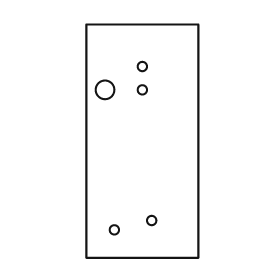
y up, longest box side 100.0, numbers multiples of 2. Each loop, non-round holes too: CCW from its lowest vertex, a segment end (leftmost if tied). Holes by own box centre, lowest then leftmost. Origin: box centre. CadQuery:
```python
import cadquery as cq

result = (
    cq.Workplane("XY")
    .moveTo(-24.0, -50.0)
    .lineTo(24.0, -50.0)
    .lineTo(24.0, 50.0)
    .lineTo(-24.0, 50.0)
    .close()
    .moveTo(-12.0, -38.0)
    .circle(2.0)
    .moveTo(4.0, -34.0)
    .circle(2.0)
    .moveTo(-16.0, 22.0)
    .circle(4.0)
    .moveTo(0.0, 22.0)
    .circle(2.0)
    .moveTo(0.0, 32.0)
    .circle(2.0)
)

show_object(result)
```